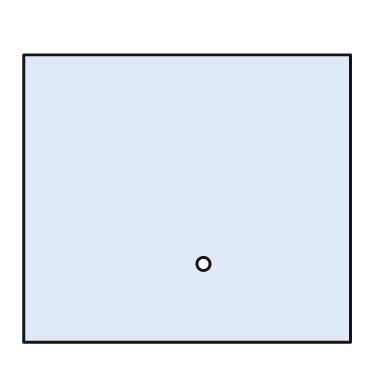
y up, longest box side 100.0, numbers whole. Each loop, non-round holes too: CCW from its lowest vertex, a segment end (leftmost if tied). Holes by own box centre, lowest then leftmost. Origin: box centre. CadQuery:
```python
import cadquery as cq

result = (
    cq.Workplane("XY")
    .moveTo(-50.0, -44.0)
    .lineTo(50.0, -44.0)
    .lineTo(50.0, 44.0)
    .lineTo(-50.0, 44.0)
    .close()
    .moveTo(5.0, -20.0)
    .circle(2.0)
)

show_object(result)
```